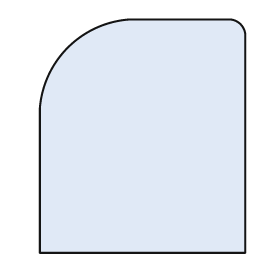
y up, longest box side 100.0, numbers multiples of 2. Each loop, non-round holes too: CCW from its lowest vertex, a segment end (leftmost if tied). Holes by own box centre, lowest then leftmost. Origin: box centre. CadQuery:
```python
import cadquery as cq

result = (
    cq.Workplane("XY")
    .moveTo(-44.0, -50.0)
    .lineTo(44.0, -50.0)
    .lineTo(44.0, 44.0)
    .threePointArc((42.0, 48.0), (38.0, 50.0))
    .lineTo(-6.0, 50.0)
    .threePointArc((-32.0, 38.0), (-44.0, 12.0))
    .close()
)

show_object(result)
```